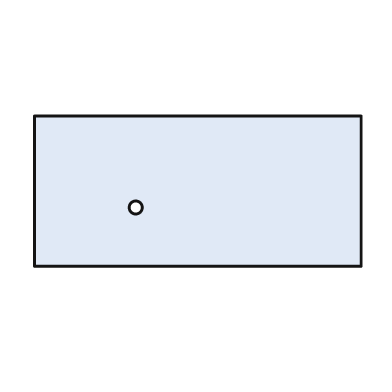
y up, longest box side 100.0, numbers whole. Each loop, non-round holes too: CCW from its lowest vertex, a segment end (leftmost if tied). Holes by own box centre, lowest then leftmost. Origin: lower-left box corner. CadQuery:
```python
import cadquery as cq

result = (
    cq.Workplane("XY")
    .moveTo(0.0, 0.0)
    .lineTo(100.0, 0.0)
    .lineTo(100.0, 46.0)
    .lineTo(0.0, 46.0)
    .close()
    .moveTo(31.0, 18.0)
    .circle(2.0)
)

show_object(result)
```